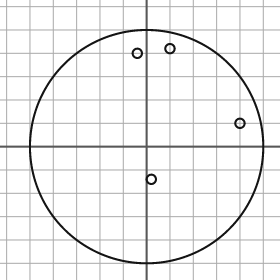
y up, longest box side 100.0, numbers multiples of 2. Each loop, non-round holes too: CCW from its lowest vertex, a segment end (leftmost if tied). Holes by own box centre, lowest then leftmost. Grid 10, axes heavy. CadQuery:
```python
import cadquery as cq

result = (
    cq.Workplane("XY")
    .moveTo(0.0, 0.0)
    .circle(50.0)
    .moveTo(2.0, -14.0)
    .circle(2.0)
    .moveTo(40.0, 10.0)
    .circle(2.0)
    .moveTo(-4.0, 40.0)
    .circle(2.0)
    .moveTo(10.0, 42.0)
    .circle(2.0)
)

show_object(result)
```